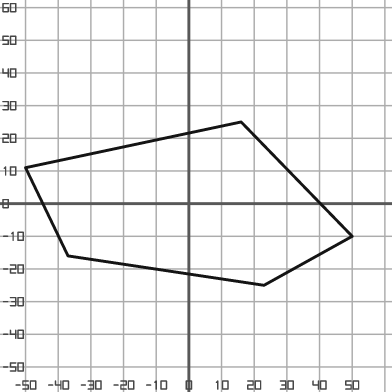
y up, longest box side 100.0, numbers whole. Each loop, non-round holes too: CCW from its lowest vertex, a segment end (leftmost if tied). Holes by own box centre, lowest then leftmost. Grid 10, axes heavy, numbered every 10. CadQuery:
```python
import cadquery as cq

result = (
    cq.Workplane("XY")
    .moveTo(23.0, -25.0)
    .lineTo(50.0, -10.0)
    .lineTo(16.0, 25.0)
    .lineTo(-50.0, 11.0)
    .lineTo(-37.0, -16.0)
    .close()
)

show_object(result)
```